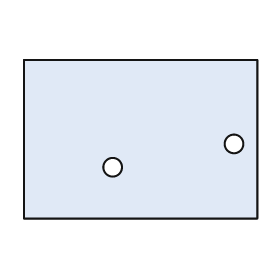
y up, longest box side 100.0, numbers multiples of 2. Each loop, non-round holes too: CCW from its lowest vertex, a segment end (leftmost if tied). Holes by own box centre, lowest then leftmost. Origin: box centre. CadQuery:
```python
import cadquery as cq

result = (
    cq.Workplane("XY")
    .moveTo(-50.0, -34.0)
    .lineTo(50.0, -34.0)
    .lineTo(50.0, 34.0)
    .lineTo(-50.0, 34.0)
    .close()
    .moveTo(-12.0, -12.0)
    .circle(4.0)
    .moveTo(40.0, -2.0)
    .circle(4.0)
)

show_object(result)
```